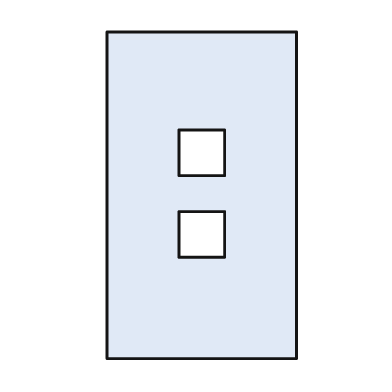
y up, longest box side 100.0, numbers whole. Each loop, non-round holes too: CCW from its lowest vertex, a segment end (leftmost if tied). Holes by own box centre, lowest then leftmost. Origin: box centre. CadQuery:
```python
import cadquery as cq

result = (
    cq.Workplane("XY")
    .moveTo(-29.0, -50.0)
    .lineTo(29.0, -50.0)
    .lineTo(29.0, 50.0)
    .lineTo(-29.0, 50.0)
    .close()
    .moveTo(-7.0, -19.0)
    .lineTo(7.0, -19.0)
    .lineTo(7.0, -5.0)
    .lineTo(-7.0, -5.0)
    .close()
    .moveTo(-7.0, 6.0)
    .lineTo(7.0, 6.0)
    .lineTo(7.0, 20.0)
    .lineTo(-7.0, 20.0)
    .close()
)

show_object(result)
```